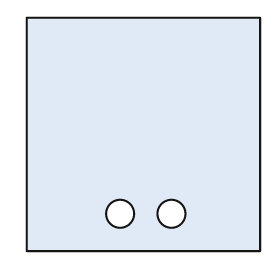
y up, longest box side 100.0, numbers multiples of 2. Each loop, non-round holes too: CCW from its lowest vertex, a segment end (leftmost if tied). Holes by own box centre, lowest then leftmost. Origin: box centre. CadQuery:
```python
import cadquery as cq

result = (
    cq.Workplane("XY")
    .moveTo(-50.0, -50.0)
    .lineTo(50.0, -50.0)
    .lineTo(50.0, 50.0)
    .lineTo(-50.0, 50.0)
    .close()
    .moveTo(-10.0, -34.0)
    .circle(6.0)
    .moveTo(12.0, -34.0)
    .circle(6.0)
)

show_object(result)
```